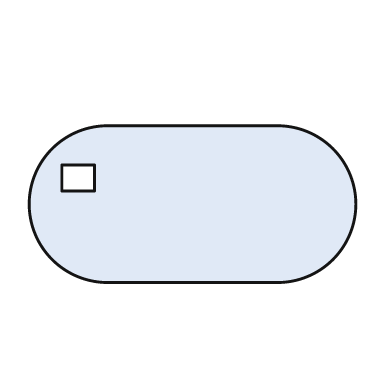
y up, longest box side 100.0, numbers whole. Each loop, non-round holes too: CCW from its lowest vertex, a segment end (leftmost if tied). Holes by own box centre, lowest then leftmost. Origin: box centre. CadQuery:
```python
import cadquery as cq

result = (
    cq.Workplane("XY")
    .moveTo(-26.0, -24.0)
    .lineTo(26.0, -24.0)
    .threePointArc((50.0, 0.0), (26.0, 24.0))
    .lineTo(-26.0, 24.0)
    .threePointArc((-50.0, 0.0), (-26.0, -24.0))
    .close()
    .moveTo(-40.0, 4.0)
    .lineTo(-30.0, 4.0)
    .lineTo(-30.0, 12.0)
    .lineTo(-40.0, 12.0)
    .close()
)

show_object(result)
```